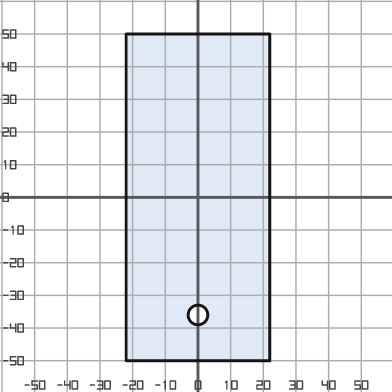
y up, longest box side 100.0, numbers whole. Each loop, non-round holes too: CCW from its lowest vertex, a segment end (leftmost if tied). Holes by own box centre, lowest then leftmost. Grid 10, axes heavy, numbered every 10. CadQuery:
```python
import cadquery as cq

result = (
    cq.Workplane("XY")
    .moveTo(-22.0, -50.0)
    .lineTo(22.0, -50.0)
    .lineTo(22.0, 50.0)
    .lineTo(-22.0, 50.0)
    .close()
    .moveTo(0.0, -36.0)
    .circle(3.0)
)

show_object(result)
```